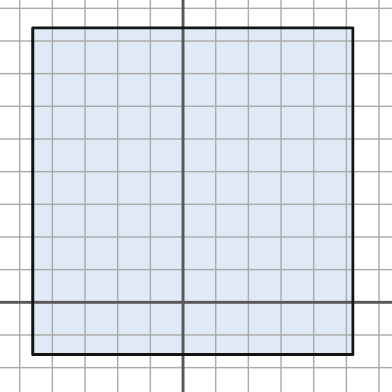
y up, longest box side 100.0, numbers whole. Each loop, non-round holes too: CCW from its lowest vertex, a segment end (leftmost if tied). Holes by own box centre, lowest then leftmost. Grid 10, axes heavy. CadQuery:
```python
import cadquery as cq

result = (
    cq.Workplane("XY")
    .moveTo(-46.0, -16.0)
    .lineTo(52.0, -16.0)
    .lineTo(52.0, 84.0)
    .lineTo(-46.0, 84.0)
    .close()
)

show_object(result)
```